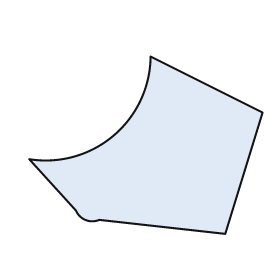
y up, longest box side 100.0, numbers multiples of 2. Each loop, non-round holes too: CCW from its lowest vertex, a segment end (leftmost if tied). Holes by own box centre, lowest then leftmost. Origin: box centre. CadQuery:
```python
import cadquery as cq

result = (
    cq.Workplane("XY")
    .moveTo(34.0, -38.0)
    .lineTo(50.0, 14.0)
    .lineTo(2.0, 38.0)
    .threePointArc((-14.0, 4.0), (-50.0, -6.0))
    .lineTo(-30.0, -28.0)
    .threePointArc((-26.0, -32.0), (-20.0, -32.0))
    .close()
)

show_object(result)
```